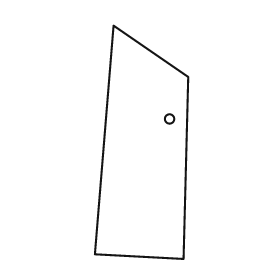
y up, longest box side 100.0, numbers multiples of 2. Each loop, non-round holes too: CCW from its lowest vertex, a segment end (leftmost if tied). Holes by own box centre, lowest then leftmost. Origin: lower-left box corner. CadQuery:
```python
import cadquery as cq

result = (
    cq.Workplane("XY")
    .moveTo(38.0, 0.0)
    .lineTo(40.0, 78.0)
    .lineTo(8.0, 100.0)
    .lineTo(0.0, 2.0)
    .close()
    .moveTo(32.0, 60.0)
    .circle(2.0)
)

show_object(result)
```